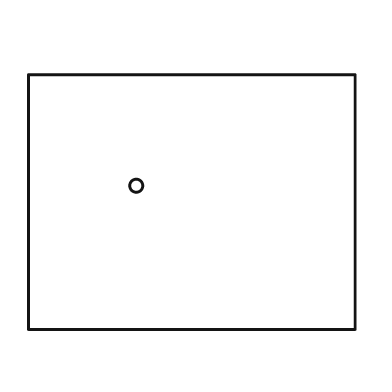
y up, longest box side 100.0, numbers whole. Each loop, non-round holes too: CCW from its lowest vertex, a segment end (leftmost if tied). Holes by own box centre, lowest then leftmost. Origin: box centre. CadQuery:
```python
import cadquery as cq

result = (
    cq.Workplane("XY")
    .moveTo(-50.0, -39.0)
    .lineTo(50.0, -39.0)
    .lineTo(50.0, 39.0)
    .lineTo(-50.0, 39.0)
    .close()
    .moveTo(-17.0, 5.0)
    .circle(2.0)
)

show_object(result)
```